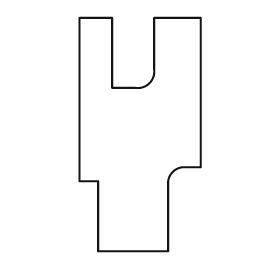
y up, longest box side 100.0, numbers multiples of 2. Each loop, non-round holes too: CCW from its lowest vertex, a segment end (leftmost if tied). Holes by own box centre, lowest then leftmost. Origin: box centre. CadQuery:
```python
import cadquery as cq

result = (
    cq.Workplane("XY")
    .moveTo(-18.0, -50.0)
    .lineTo(12.0, -50.0)
    .lineTo(12.0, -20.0)
    .threePointArc((14.0, -16.0), (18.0, -14.0))
    .lineTo(26.0, -14.0)
    .lineTo(26.0, 50.0)
    .lineTo(6.0, 50.0)
    .lineTo(6.0, 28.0)
    .threePointArc((4.0, 22.0), (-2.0, 20.0))
    .lineTo(-12.0, 20.0)
    .lineTo(-12.0, 50.0)
    .lineTo(-26.0, 50.0)
    .lineTo(-26.0, -20.0)
    .lineTo(-18.0, -20.0)
    .close()
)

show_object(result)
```